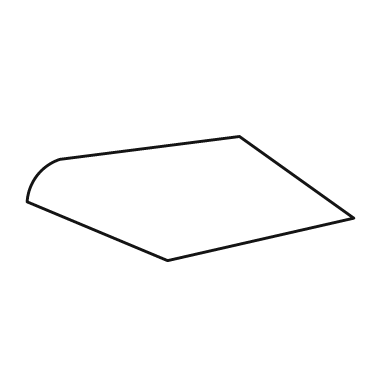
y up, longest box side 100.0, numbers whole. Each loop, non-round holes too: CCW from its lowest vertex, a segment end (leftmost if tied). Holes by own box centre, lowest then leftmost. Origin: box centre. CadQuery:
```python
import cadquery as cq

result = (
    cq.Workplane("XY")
    .moveTo(-7.0, -19.0)
    .lineTo(50.0, -6.0)
    .lineTo(15.0, 19.0)
    .lineTo(-40.0, 12.0)
    .threePointArc((-47.0, 7.0), (-50.0, -1.0))
    .close()
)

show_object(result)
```